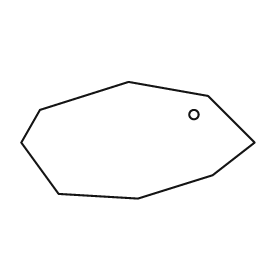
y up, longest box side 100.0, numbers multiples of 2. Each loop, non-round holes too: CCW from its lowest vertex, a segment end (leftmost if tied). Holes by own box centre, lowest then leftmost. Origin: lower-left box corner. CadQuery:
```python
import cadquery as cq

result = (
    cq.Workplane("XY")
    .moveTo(50.0, 0.0)
    .lineTo(82.0, 10.0)
    .lineTo(100.0, 24.0)
    .lineTo(80.0, 44.0)
    .lineTo(46.0, 50.0)
    .lineTo(8.0, 38.0)
    .lineTo(0.0, 24.0)
    .lineTo(16.0, 2.0)
    .close()
    .moveTo(74.0, 36.0)
    .circle(2.0)
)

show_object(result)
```